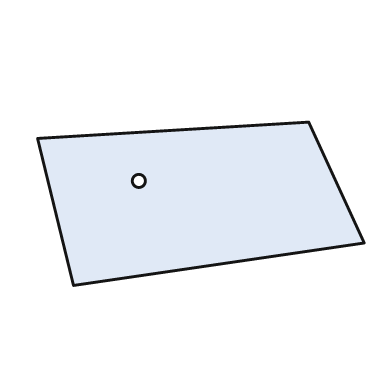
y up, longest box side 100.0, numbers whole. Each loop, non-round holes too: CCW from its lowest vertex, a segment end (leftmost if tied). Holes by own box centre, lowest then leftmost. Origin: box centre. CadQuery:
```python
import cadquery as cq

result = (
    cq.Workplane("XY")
    .moveTo(-39.0, -25.0)
    .lineTo(50.0, -12.0)
    .lineTo(33.0, 25.0)
    .lineTo(-50.0, 20.0)
    .close()
    .moveTo(-19.0, 7.0)
    .circle(2.0)
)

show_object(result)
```